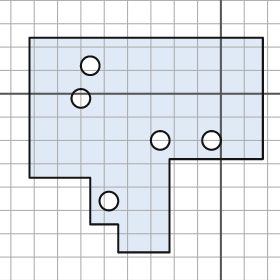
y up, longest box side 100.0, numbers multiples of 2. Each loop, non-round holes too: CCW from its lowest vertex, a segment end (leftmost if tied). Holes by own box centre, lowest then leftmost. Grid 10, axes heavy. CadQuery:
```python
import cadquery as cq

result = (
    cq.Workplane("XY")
    .moveTo(-44.0, -68.0)
    .lineTo(-22.0, -68.0)
    .lineTo(-22.0, -28.0)
    .lineTo(18.0, -28.0)
    .lineTo(18.0, 24.0)
    .lineTo(-82.0, 24.0)
    .lineTo(-82.0, -36.0)
    .lineTo(-56.0, -36.0)
    .lineTo(-56.0, -56.0)
    .lineTo(-44.0, -56.0)
    .close()
    .moveTo(-48.0, -46.0)
    .circle(4.0)
    .moveTo(-26.0, -20.0)
    .circle(4.0)
    .moveTo(-4.0, -20.0)
    .circle(4.0)
    .moveTo(-60.0, -2.0)
    .circle(4.0)
    .moveTo(-56.0, 12.0)
    .circle(4.0)
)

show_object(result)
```